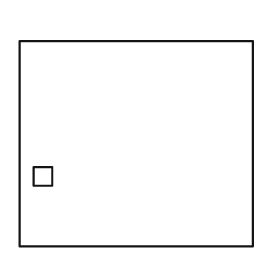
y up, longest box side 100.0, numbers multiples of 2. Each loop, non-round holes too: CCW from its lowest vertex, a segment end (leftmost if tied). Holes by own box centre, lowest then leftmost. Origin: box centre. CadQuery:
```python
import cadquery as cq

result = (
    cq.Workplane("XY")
    .moveTo(-50.0, -44.0)
    .lineTo(50.0, -44.0)
    .lineTo(50.0, 44.0)
    .lineTo(-50.0, 44.0)
    .close()
    .moveTo(-44.0, -18.0)
    .lineTo(-36.0, -18.0)
    .lineTo(-36.0, -10.0)
    .lineTo(-44.0, -10.0)
    .close()
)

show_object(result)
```